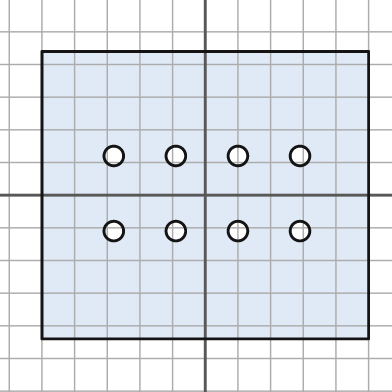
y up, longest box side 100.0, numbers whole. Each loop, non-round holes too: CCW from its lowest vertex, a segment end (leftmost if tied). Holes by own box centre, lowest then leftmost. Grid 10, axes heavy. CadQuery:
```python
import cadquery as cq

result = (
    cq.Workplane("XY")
    .moveTo(-50.0, -44.0)
    .lineTo(50.0, -44.0)
    .lineTo(50.0, 44.0)
    .lineTo(-50.0, 44.0)
    .close()
    .moveTo(-28.0, -11.0)
    .circle(3.0)
    .moveTo(-9.0, -11.0)
    .circle(3.0)
    .moveTo(10.0, -11.0)
    .circle(3.0)
    .moveTo(29.0, -11.0)
    .circle(3.0)
    .moveTo(-28.0, 12.0)
    .circle(3.0)
    .moveTo(-9.0, 12.0)
    .circle(3.0)
    .moveTo(10.0, 12.0)
    .circle(3.0)
    .moveTo(29.0, 12.0)
    .circle(3.0)
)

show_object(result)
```